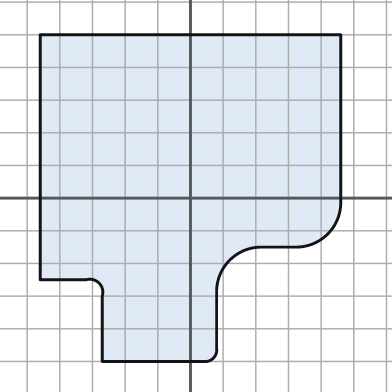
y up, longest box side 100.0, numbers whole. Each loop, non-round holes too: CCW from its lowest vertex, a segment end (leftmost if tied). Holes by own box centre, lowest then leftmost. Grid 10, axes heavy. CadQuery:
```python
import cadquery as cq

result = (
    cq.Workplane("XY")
    .moveTo(-27.0, -50.0)
    .lineTo(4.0, -50.0)
    .threePointArc((7.0, -49.0), (8.0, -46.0))
    .lineTo(8.0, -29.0)
    .threePointArc((12.0, -19.0), (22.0, -15.0))
    .lineTo(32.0, -15.0)
    .threePointArc((42.0, -11.0), (46.0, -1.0))
    .lineTo(46.0, 50.0)
    .lineTo(-46.0, 50.0)
    .lineTo(-46.0, -25.0)
    .lineTo(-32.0, -25.0)
    .threePointArc((-28.0, -26.0), (-27.0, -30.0))
    .close()
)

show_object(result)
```